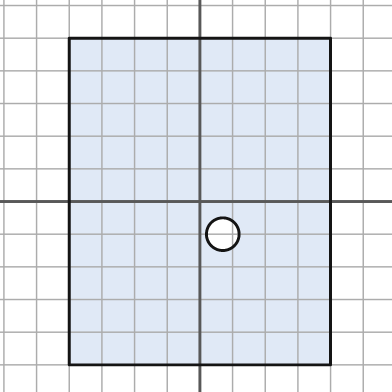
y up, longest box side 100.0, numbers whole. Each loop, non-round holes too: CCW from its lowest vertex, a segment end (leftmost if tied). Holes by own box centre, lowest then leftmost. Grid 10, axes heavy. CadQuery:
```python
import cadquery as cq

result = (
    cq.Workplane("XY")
    .moveTo(-40.0, -50.0)
    .lineTo(40.0, -50.0)
    .lineTo(40.0, 50.0)
    .lineTo(-40.0, 50.0)
    .close()
    .moveTo(7.0, -10.0)
    .circle(5.0)
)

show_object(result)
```